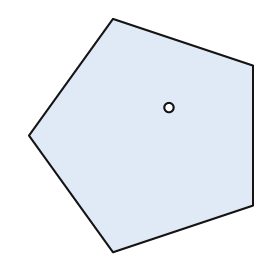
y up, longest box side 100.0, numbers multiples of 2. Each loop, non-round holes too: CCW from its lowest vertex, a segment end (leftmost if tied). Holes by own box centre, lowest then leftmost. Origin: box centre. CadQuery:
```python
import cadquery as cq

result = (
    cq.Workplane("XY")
    .moveTo(-12.0, -50.0)
    .lineTo(48.0, -30.0)
    .lineTo(48.0, 30.0)
    .lineTo(-12.0, 50.0)
    .lineTo(-48.0, 0.0)
    .close()
    .moveTo(12.0, 12.0)
    .circle(2.0)
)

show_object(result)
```